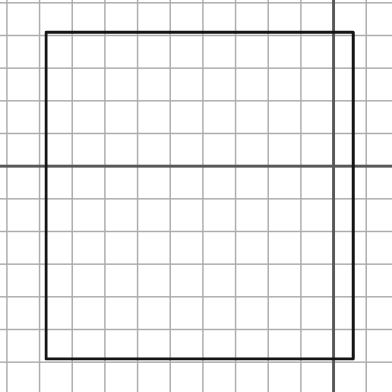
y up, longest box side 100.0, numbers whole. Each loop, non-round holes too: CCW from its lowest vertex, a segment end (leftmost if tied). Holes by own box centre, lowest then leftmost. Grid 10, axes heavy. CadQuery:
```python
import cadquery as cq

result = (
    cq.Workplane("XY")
    .moveTo(-88.0, -59.0)
    .lineTo(6.0, -59.0)
    .lineTo(6.0, 41.0)
    .lineTo(-88.0, 41.0)
    .close()
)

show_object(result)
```